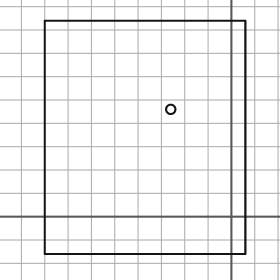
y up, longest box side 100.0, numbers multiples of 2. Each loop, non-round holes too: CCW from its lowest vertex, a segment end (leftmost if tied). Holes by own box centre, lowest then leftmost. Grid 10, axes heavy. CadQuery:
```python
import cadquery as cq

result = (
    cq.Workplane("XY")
    .moveTo(-80.0, -16.0)
    .lineTo(6.0, -16.0)
    .lineTo(6.0, 84.0)
    .lineTo(-80.0, 84.0)
    .close()
    .moveTo(-26.0, 46.0)
    .circle(2.0)
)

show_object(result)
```